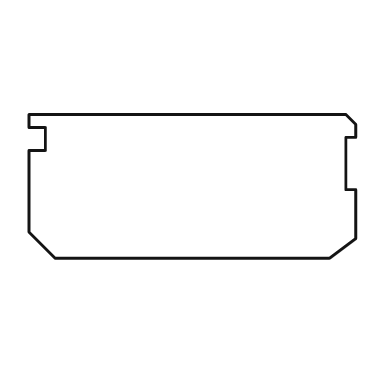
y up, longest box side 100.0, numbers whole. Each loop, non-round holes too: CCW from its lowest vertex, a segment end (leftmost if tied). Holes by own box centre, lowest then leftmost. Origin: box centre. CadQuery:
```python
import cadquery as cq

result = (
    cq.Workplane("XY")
    .moveTo(-42.0, -22.0)
    .lineTo(42.0, -22.0)
    .lineTo(50.0, -16.0)
    .lineTo(50.0, -1.0)
    .lineTo(47.0, -1.0)
    .lineTo(47.0, 15.0)
    .lineTo(50.0, 15.0)
    .lineTo(50.0, 19.0)
    .lineTo(47.0, 22.0)
    .lineTo(-50.0, 22.0)
    .lineTo(-50.0, 18.0)
    .lineTo(-45.0, 18.0)
    .lineTo(-45.0, 11.0)
    .lineTo(-50.0, 11.0)
    .lineTo(-50.0, -14.0)
    .close()
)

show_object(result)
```